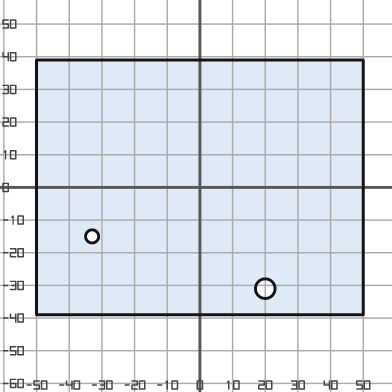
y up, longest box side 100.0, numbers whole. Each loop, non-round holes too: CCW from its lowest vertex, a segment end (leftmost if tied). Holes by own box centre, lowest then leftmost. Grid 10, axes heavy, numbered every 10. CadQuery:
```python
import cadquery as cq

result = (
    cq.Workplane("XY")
    .moveTo(-50.0, -39.0)
    .lineTo(50.0, -39.0)
    .lineTo(50.0, 39.0)
    .lineTo(-50.0, 39.0)
    .close()
    .moveTo(20.0, -31.0)
    .circle(3.0)
    .moveTo(-33.0, -15.0)
    .circle(2.0)
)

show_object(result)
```